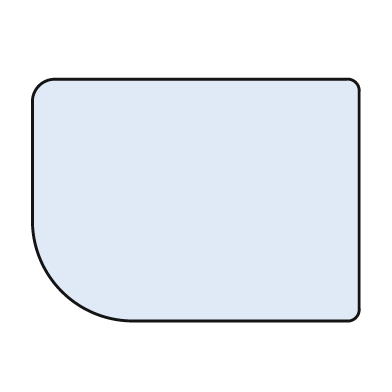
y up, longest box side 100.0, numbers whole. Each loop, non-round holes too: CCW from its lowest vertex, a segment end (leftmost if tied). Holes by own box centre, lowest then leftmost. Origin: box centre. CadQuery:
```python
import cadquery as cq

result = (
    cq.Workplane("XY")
    .moveTo(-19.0, -37.0)
    .lineTo(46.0, -37.0)
    .threePointArc((49.0, -36.0), (50.0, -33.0))
    .lineTo(50.0, 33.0)
    .threePointArc((49.0, 36.0), (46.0, 37.0))
    .lineTo(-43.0, 37.0)
    .threePointArc((-48.0, 35.0), (-50.0, 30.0))
    .lineTo(-50.0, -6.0)
    .threePointArc((-41.0, -28.0), (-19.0, -37.0))
    .close()
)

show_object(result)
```